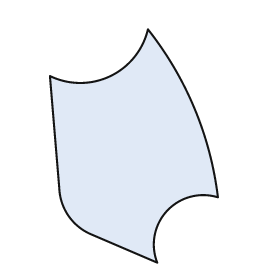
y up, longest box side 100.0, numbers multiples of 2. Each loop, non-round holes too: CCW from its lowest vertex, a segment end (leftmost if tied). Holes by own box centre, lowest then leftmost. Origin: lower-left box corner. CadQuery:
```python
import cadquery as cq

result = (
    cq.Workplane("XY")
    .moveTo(46.0, 0.0)
    .threePointArc((50.0, 22.0), (72.0, 28.0))
    .threePointArc((62.0, 66.0), (42.0, 100.0))
    .threePointArc((26.0, 80.0), (0.0, 80.0))
    .lineTo(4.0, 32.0)
    .threePointArc((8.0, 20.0), (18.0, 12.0))
    .close()
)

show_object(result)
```